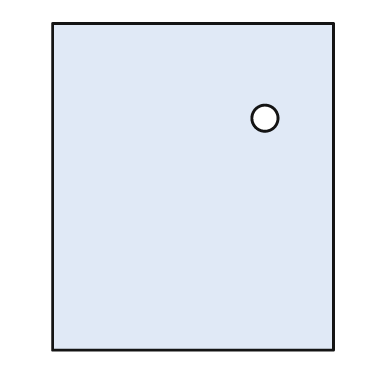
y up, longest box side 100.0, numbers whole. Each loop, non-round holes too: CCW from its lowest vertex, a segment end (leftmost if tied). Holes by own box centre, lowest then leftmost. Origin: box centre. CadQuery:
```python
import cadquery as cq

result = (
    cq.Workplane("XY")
    .moveTo(-43.0, -50.0)
    .lineTo(43.0, -50.0)
    .lineTo(43.0, 50.0)
    .lineTo(-43.0, 50.0)
    .close()
    .moveTo(22.0, 21.0)
    .circle(4.0)
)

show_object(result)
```